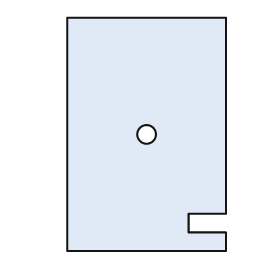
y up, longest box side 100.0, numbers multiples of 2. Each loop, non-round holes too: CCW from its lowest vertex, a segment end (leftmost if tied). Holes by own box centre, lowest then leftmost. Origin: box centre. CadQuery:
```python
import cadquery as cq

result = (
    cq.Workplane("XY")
    .moveTo(-34.0, -50.0)
    .lineTo(34.0, -50.0)
    .lineTo(34.0, -42.0)
    .lineTo(18.0, -42.0)
    .lineTo(18.0, -34.0)
    .lineTo(34.0, -34.0)
    .lineTo(34.0, 50.0)
    .lineTo(-34.0, 50.0)
    .close()
    .moveTo(0.0, 0.0)
    .circle(4.0)
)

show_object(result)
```